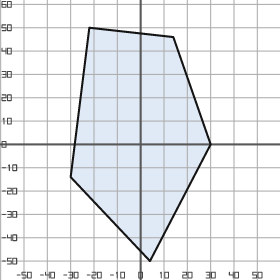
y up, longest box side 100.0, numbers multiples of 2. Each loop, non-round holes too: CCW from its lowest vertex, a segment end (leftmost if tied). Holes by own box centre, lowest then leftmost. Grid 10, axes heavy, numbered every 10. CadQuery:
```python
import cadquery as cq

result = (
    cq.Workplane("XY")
    .moveTo(4.0, -50.0)
    .lineTo(30.0, 0.0)
    .lineTo(14.0, 46.0)
    .lineTo(-22.0, 50.0)
    .lineTo(-30.0, -14.0)
    .close()
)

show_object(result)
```